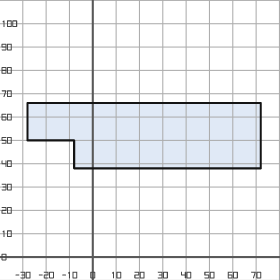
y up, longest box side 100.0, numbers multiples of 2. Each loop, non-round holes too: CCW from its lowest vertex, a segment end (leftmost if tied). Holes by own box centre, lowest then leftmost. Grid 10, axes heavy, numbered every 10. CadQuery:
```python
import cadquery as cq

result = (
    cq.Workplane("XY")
    .moveTo(-8.0, 38.0)
    .lineTo(72.0, 38.0)
    .lineTo(72.0, 66.0)
    .lineTo(-28.0, 66.0)
    .lineTo(-28.0, 50.0)
    .lineTo(-8.0, 50.0)
    .close()
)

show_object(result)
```